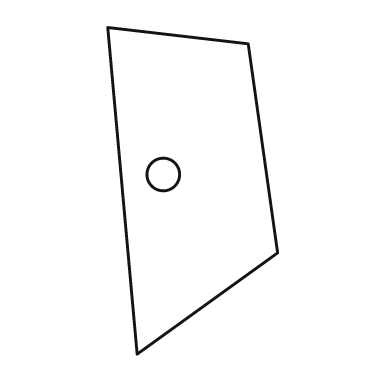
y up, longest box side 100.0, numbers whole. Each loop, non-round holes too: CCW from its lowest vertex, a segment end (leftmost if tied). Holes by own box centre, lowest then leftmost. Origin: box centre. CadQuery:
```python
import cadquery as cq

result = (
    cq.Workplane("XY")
    .moveTo(-17.0, -50.0)
    .lineTo(26.0, -19.0)
    .lineTo(17.0, 45.0)
    .lineTo(-26.0, 50.0)
    .close()
    .moveTo(-9.0, 5.0)
    .circle(5.0)
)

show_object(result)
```